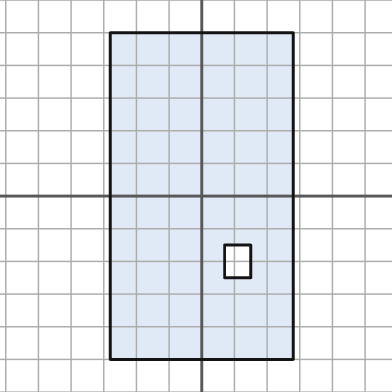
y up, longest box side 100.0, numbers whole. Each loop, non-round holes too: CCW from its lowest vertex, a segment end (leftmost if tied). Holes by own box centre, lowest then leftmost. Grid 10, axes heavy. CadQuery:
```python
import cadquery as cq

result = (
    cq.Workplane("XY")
    .moveTo(-28.0, -50.0)
    .lineTo(28.0, -50.0)
    .lineTo(28.0, 50.0)
    .lineTo(-28.0, 50.0)
    .close()
    .moveTo(7.0, -25.0)
    .lineTo(15.0, -25.0)
    .lineTo(15.0, -15.0)
    .lineTo(7.0, -15.0)
    .close()
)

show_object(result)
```